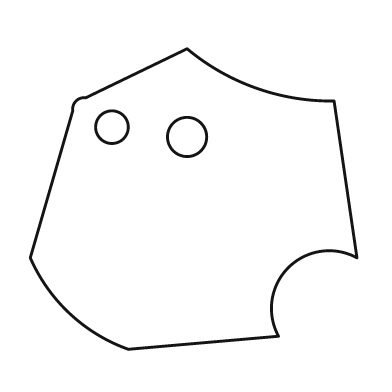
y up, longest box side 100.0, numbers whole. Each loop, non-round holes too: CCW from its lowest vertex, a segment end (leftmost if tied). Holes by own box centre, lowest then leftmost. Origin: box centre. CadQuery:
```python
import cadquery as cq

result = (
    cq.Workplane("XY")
    .moveTo(-20.0, -46.0)
    .lineTo(26.0, -42.0)
    .threePointArc((29.0, -21.0), (50.0, -18.0))
    .lineTo(43.0, 30.0)
    .threePointArc((19.0, 34.0), (-2.0, 46.0))
    .lineTo(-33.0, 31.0)
    .threePointArc((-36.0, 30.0), (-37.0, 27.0))
    .lineTo(-50.0, -18.0)
    .threePointArc((-38.0, -35.0), (-20.0, -46.0))
    .close()
    .moveTo(-2.0, 19.0)
    .circle(6.0)
    .moveTo(-25.0, 22.0)
    .circle(5.0)
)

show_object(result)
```